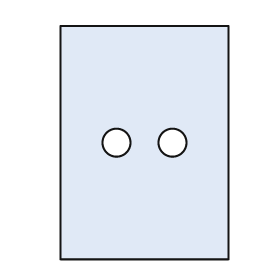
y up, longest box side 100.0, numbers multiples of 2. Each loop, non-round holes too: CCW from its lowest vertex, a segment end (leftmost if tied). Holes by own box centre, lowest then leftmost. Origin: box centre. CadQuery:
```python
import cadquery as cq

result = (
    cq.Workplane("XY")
    .moveTo(-36.0, -50.0)
    .lineTo(36.0, -50.0)
    .lineTo(36.0, 50.0)
    .lineTo(-36.0, 50.0)
    .close()
    .moveTo(-12.0, 0.0)
    .circle(6.0)
    .moveTo(12.0, 0.0)
    .circle(6.0)
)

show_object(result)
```